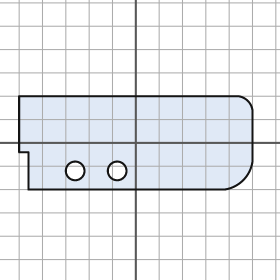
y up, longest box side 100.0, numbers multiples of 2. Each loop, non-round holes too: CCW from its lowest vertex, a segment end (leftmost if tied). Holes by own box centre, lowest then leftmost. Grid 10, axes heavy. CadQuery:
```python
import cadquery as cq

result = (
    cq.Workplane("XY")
    .moveTo(-46.0, -20.0)
    .lineTo(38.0, -20.0)
    .threePointArc((46.0, -16.0), (50.0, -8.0))
    .lineTo(50.0, 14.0)
    .threePointArc((48.0, 18.0), (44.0, 20.0))
    .lineTo(-50.0, 20.0)
    .lineTo(-50.0, -4.0)
    .lineTo(-46.0, -4.0)
    .close()
    .moveTo(-26.0, -12.0)
    .circle(4.0)
    .moveTo(-8.0, -12.0)
    .circle(4.0)
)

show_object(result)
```